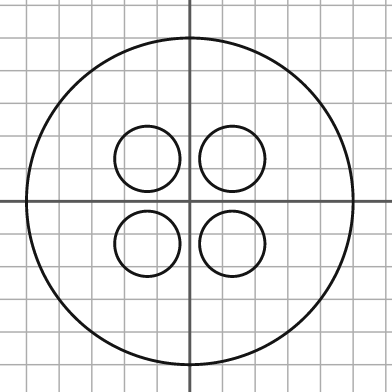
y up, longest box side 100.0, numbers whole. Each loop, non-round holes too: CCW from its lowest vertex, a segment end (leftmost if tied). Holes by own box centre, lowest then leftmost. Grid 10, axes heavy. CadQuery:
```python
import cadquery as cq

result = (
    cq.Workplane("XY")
    .moveTo(0.0, 0.0)
    .circle(50.0)
    .moveTo(-13.0, -13.0)
    .circle(10.0)
    .moveTo(13.0, -13.0)
    .circle(10.0)
    .moveTo(-13.0, 13.0)
    .circle(10.0)
    .moveTo(13.0, 13.0)
    .circle(10.0)
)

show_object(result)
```